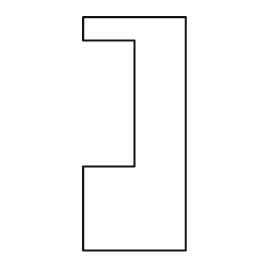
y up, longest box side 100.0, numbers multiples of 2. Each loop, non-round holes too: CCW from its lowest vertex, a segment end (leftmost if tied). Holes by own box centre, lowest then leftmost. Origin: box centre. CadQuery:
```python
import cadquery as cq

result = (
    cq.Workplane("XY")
    .moveTo(-22.0, -50.0)
    .lineTo(22.0, -50.0)
    .lineTo(22.0, 50.0)
    .lineTo(-22.0, 50.0)
    .lineTo(-22.0, 40.0)
    .lineTo(0.0, 40.0)
    .lineTo(0.0, -14.0)
    .lineTo(-22.0, -14.0)
    .close()
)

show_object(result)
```